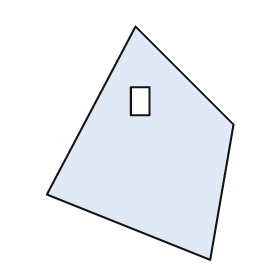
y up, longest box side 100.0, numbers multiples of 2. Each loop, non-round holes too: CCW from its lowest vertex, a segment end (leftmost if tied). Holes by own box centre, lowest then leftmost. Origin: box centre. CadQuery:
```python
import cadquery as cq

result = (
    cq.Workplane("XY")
    .moveTo(30.0, -50.0)
    .lineTo(40.0, 8.0)
    .lineTo(-2.0, 50.0)
    .lineTo(-40.0, -22.0)
    .close()
    .moveTo(-4.0, 12.0)
    .lineTo(4.0, 12.0)
    .lineTo(4.0, 24.0)
    .lineTo(-4.0, 24.0)
    .close()
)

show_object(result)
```